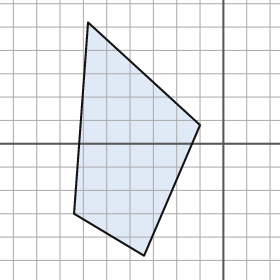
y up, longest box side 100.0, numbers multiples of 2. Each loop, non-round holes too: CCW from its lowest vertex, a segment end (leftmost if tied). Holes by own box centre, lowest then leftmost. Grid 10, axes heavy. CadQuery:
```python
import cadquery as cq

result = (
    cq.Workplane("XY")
    .moveTo(-34.0, -48.0)
    .lineTo(-10.0, 8.0)
    .lineTo(-58.0, 52.0)
    .lineTo(-64.0, -30.0)
    .close()
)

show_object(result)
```